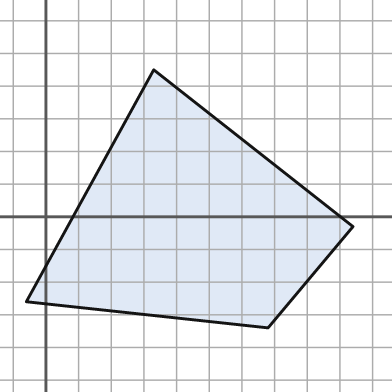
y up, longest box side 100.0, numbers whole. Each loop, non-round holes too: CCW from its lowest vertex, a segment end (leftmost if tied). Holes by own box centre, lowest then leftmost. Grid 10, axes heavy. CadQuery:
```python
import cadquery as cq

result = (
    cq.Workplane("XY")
    .moveTo(68.0, -34.0)
    .lineTo(94.0, -3.0)
    .lineTo(33.0, 45.0)
    .lineTo(-6.0, -26.0)
    .close()
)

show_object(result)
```